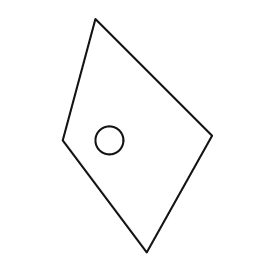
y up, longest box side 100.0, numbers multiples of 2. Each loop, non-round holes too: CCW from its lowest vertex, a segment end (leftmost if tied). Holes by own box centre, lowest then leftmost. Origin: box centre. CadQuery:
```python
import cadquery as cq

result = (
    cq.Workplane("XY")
    .moveTo(4.0, -50.0)
    .lineTo(32.0, 0.0)
    .lineTo(-18.0, 50.0)
    .lineTo(-32.0, -2.0)
    .close()
    .moveTo(-12.0, -2.0)
    .circle(6.0)
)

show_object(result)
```